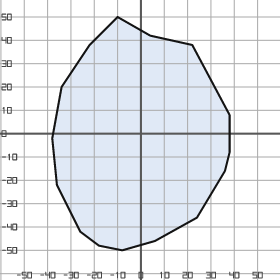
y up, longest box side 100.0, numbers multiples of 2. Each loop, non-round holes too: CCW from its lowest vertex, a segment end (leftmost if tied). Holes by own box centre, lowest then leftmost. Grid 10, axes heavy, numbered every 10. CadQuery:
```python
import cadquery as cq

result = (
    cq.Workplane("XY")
    .moveTo(-8.0, -50.0)
    .lineTo(6.0, -46.0)
    .lineTo(24.0, -36.0)
    .lineTo(36.0, -16.0)
    .lineTo(38.0, -8.0)
    .lineTo(38.0, 8.0)
    .lineTo(22.0, 38.0)
    .lineTo(4.0, 42.0)
    .lineTo(-10.0, 50.0)
    .lineTo(-22.0, 38.0)
    .lineTo(-34.0, 20.0)
    .lineTo(-38.0, -2.0)
    .lineTo(-36.0, -22.0)
    .lineTo(-26.0, -42.0)
    .lineTo(-18.0, -48.0)
    .close()
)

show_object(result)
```